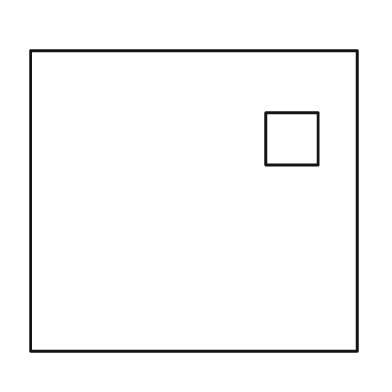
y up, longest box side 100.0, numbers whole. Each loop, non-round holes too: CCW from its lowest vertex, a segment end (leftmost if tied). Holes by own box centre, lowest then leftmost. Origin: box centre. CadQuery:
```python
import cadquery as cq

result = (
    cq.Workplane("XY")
    .moveTo(-50.0, -46.0)
    .lineTo(50.0, -46.0)
    .lineTo(50.0, 46.0)
    .lineTo(-50.0, 46.0)
    .close()
    .moveTo(22.0, 11.0)
    .lineTo(38.0, 11.0)
    .lineTo(38.0, 27.0)
    .lineTo(22.0, 27.0)
    .close()
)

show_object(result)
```